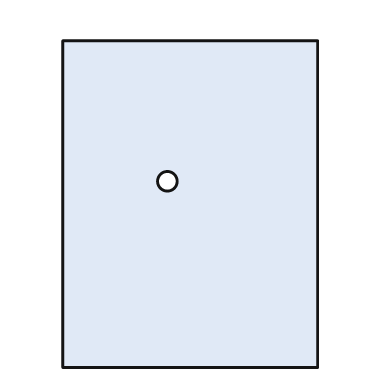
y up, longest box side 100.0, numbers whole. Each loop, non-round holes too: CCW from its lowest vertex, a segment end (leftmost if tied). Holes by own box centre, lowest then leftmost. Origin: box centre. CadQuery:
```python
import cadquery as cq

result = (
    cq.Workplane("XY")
    .moveTo(-39.0, -50.0)
    .lineTo(39.0, -50.0)
    .lineTo(39.0, 50.0)
    .lineTo(-39.0, 50.0)
    .close()
    .moveTo(-7.0, 7.0)
    .circle(3.0)
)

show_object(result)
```